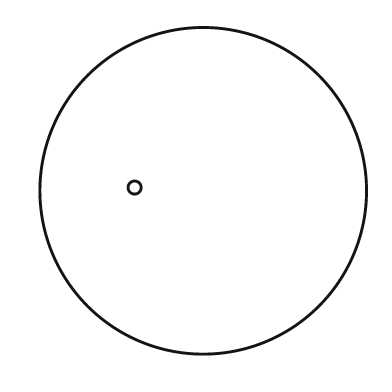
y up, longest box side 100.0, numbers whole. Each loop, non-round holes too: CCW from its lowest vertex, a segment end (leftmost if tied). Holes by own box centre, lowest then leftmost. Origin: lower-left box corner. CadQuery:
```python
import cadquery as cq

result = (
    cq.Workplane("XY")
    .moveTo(50.0, 50.0)
    .circle(50.0)
    .moveTo(29.0, 51.0)
    .circle(2.0)
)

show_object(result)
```